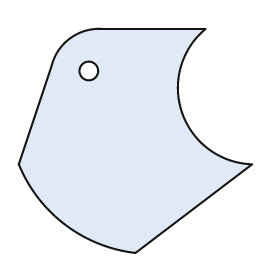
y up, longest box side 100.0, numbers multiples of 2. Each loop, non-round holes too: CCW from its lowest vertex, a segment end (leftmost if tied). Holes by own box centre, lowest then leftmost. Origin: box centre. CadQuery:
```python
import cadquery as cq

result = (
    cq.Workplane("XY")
    .moveTo(0.0, -48.0)
    .lineTo(50.0, -10.0)
    .threePointArc((20.0, 12.0), (30.0, 48.0))
    .lineTo(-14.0, 48.0)
    .threePointArc((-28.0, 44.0), (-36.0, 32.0))
    .lineTo(-50.0, -10.0)
    .threePointArc((-30.0, -36.0), (0.0, -48.0))
    .close()
    .moveTo(-20.0, 30.0)
    .circle(4.0)
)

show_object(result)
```